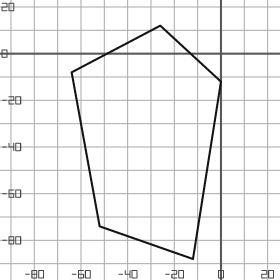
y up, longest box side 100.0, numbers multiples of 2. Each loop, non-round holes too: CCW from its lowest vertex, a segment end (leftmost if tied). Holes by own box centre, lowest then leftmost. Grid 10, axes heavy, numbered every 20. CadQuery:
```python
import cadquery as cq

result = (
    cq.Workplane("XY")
    .moveTo(-12.0, -88.0)
    .lineTo(0.0, -12.0)
    .lineTo(-26.0, 12.0)
    .lineTo(-64.0, -8.0)
    .lineTo(-52.0, -74.0)
    .close()
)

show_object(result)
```